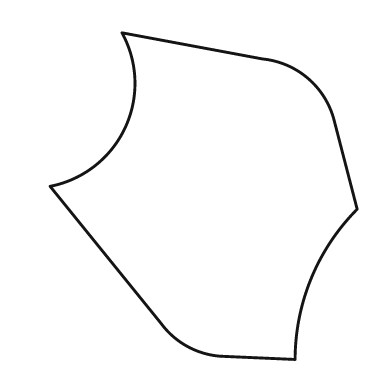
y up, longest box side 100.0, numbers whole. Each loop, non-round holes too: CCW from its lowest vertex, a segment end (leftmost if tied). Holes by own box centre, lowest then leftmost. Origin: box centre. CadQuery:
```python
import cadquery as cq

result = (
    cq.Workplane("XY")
    .moveTo(28.0, -50.0)
    .threePointArc((33.0, -25.0), (47.0, -4.0))
    .lineTo(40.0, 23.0)
    .threePointArc((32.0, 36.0), (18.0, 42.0))
    .lineTo(-25.0, 50.0)
    .threePointArc((-24.0, 21.0), (-47.0, 3.0))
    .lineTo(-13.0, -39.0)
    .threePointArc((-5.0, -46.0), (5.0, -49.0))
    .close()
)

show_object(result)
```